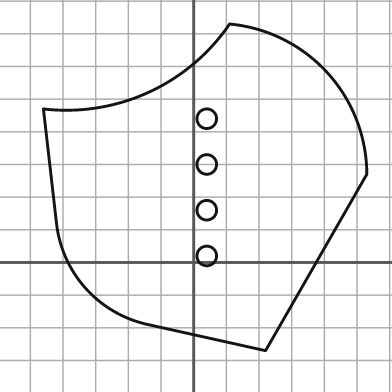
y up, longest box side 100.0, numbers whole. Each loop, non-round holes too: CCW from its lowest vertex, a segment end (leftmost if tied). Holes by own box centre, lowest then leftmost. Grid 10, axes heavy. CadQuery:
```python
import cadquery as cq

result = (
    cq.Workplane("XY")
    .moveTo(22.0, -27.0)
    .lineTo(53.0, 27.0)
    .threePointArc((41.0, 58.0), (11.0, 73.0))
    .threePointArc((-14.0, 52.0), (-46.0, 47.0))
    .lineTo(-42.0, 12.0)
    .threePointArc((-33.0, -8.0), (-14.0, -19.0))
    .close()
    .moveTo(4.0, 2.0)
    .circle(3.0)
    .moveTo(4.0, 16.0)
    .circle(3.0)
    .moveTo(4.0, 30.0)
    .circle(3.0)
    .moveTo(4.0, 44.0)
    .circle(3.0)
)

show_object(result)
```